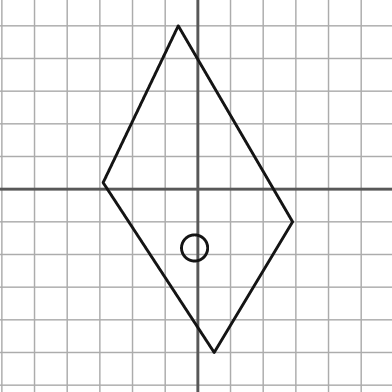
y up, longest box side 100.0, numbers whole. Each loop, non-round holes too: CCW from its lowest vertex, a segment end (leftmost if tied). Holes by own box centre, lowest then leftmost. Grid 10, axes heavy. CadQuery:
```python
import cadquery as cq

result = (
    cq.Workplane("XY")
    .moveTo(5.0, -50.0)
    .lineTo(29.0, -10.0)
    .lineTo(-6.0, 50.0)
    .lineTo(-29.0, 2.0)
    .close()
    .moveTo(-1.0, -18.0)
    .circle(4.0)
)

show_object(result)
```